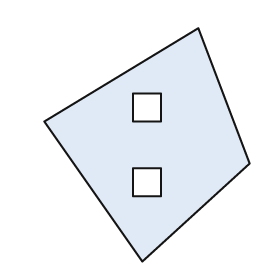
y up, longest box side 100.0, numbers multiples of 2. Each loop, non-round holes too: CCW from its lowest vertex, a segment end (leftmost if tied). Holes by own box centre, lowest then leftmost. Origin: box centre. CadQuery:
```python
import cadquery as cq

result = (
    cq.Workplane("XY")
    .moveTo(-2.0, -50.0)
    .lineTo(44.0, -8.0)
    .lineTo(22.0, 50.0)
    .lineTo(-44.0, 10.0)
    .close()
    .moveTo(-6.0, -22.0)
    .lineTo(6.0, -22.0)
    .lineTo(6.0, -10.0)
    .lineTo(-6.0, -10.0)
    .close()
    .moveTo(-6.0, 10.0)
    .lineTo(6.0, 10.0)
    .lineTo(6.0, 22.0)
    .lineTo(-6.0, 22.0)
    .close()
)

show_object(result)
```